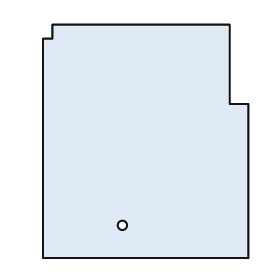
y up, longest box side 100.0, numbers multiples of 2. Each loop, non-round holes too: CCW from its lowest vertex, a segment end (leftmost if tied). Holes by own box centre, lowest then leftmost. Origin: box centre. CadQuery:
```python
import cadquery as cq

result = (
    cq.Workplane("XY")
    .moveTo(-44.0, -50.0)
    .lineTo(44.0, -50.0)
    .lineTo(44.0, 16.0)
    .lineTo(36.0, 16.0)
    .lineTo(36.0, 50.0)
    .lineTo(-40.0, 50.0)
    .lineTo(-40.0, 44.0)
    .lineTo(-44.0, 44.0)
    .close()
    .moveTo(-10.0, -36.0)
    .circle(2.0)
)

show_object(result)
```